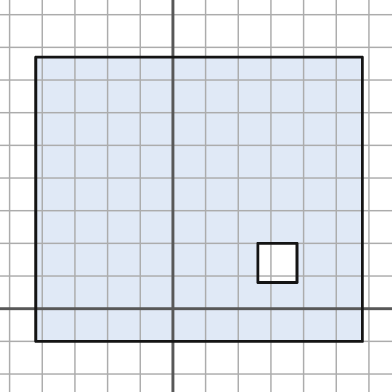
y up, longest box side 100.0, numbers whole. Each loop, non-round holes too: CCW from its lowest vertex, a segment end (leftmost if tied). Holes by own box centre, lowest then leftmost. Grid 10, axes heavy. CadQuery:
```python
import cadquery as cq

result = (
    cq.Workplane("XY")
    .moveTo(-42.0, -10.0)
    .lineTo(58.0, -10.0)
    .lineTo(58.0, 77.0)
    .lineTo(-42.0, 77.0)
    .close()
    .moveTo(26.0, 8.0)
    .lineTo(38.0, 8.0)
    .lineTo(38.0, 20.0)
    .lineTo(26.0, 20.0)
    .close()
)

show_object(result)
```